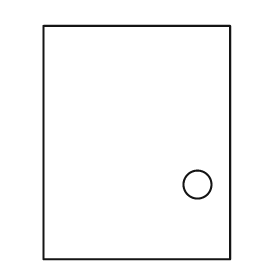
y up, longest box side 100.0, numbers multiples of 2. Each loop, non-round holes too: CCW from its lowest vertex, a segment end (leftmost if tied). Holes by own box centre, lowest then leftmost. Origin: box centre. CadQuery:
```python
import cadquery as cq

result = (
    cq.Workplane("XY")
    .moveTo(-40.0, -50.0)
    .lineTo(40.0, -50.0)
    .lineTo(40.0, 50.0)
    .lineTo(-40.0, 50.0)
    .close()
    .moveTo(26.0, -18.0)
    .circle(6.0)
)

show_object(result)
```